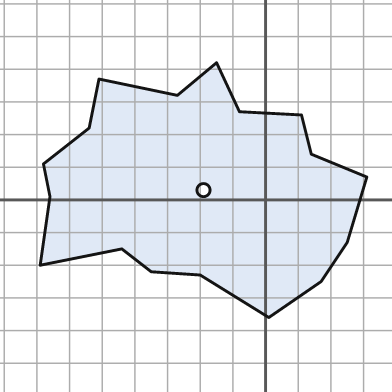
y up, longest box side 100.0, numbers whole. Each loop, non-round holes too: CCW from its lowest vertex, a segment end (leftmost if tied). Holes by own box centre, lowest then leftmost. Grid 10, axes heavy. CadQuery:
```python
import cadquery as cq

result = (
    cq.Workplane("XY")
    .moveTo(1.0, -36.0)
    .lineTo(17.0, -25.0)
    .lineTo(25.0, -13.0)
    .lineTo(31.0, 7.0)
    .lineTo(14.0, 14.0)
    .lineTo(11.0, 26.0)
    .lineTo(-8.0, 27.0)
    .lineTo(-15.0, 42.0)
    .lineTo(-27.0, 32.0)
    .lineTo(-51.0, 37.0)
    .lineTo(-54.0, 22.0)
    .lineTo(-68.0, 11.0)
    .lineTo(-66.0, 1.0)
    .lineTo(-69.0, -20.0)
    .lineTo(-44.0, -15.0)
    .lineTo(-35.0, -22.0)
    .lineTo(-20.0, -23.0)
    .close()
    .moveTo(-19.0, 3.0)
    .circle(2.0)
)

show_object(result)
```